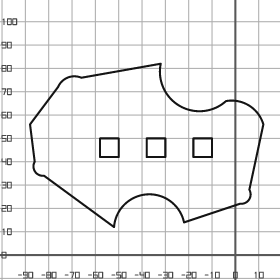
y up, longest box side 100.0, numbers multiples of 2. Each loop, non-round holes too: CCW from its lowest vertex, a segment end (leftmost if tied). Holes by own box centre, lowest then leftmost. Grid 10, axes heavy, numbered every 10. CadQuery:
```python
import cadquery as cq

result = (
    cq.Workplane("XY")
    .moveTo(-52.0, 12.0)
    .threePointArc((-38.0, 26.0), (-22.0, 14.0))
    .lineTo(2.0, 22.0)
    .threePointArc((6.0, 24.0), (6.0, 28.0))
    .lineTo(12.0, 56.0)
    .threePointArc((6.0, 64.0), (-4.0, 66.0))
    .threePointArc((-24.0, 64.0), (-32.0, 82.0))
    .lineTo(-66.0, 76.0)
    .threePointArc((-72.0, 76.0), (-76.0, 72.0))
    .lineTo(-88.0, 56.0)
    .lineTo(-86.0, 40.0)
    .threePointArc((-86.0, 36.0), (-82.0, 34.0))
    .close()
    .moveTo(-58.0, 42.0)
    .lineTo(-50.0, 42.0)
    .lineTo(-50.0, 50.0)
    .lineTo(-58.0, 50.0)
    .close()
    .moveTo(-38.0, 42.0)
    .lineTo(-30.0, 42.0)
    .lineTo(-30.0, 50.0)
    .lineTo(-38.0, 50.0)
    .close()
    .moveTo(-18.0, 42.0)
    .lineTo(-10.0, 42.0)
    .lineTo(-10.0, 50.0)
    .lineTo(-18.0, 50.0)
    .close()
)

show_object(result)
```